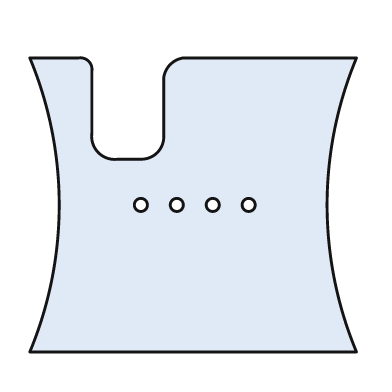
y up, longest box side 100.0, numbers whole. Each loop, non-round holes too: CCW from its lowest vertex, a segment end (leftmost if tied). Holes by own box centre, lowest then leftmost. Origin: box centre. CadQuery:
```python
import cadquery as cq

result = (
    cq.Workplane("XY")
    .moveTo(-50.0, -45.0)
    .lineTo(50.0, -45.0)
    .threePointArc((41.0, 0.0), (50.0, 45.0))
    .lineTo(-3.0, 45.0)
    .threePointArc((-7.0, 43.0), (-9.0, 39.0))
    .lineTo(-9.0, 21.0)
    .threePointArc((-11.0, 16.0), (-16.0, 14.0))
    .lineTo(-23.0, 14.0)
    .threePointArc((-29.0, 16.0), (-31.0, 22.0))
    .lineTo(-31.0, 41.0)
    .threePointArc((-32.0, 44.0), (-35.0, 45.0))
    .lineTo(-50.0, 45.0)
    .threePointArc((-41.0, 0.0), (-50.0, -45.0))
    .close()
    .moveTo(-16.0, 0.0)
    .circle(2.0)
    .moveTo(-5.0, 0.0)
    .circle(2.0)
    .moveTo(6.0, 0.0)
    .circle(2.0)
    .moveTo(17.0, 0.0)
    .circle(2.0)
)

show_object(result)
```